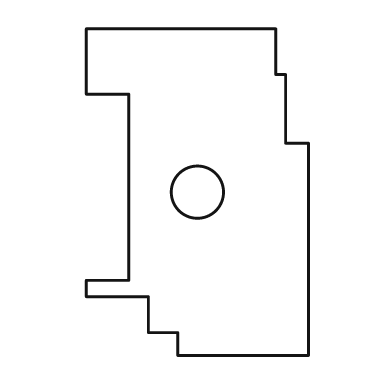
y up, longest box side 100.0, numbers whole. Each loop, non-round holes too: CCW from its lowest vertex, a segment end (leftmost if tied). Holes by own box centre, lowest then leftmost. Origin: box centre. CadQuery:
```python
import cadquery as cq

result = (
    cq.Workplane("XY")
    .moveTo(-6.0, -50.0)
    .lineTo(34.0, -50.0)
    .lineTo(34.0, 15.0)
    .lineTo(27.0, 15.0)
    .lineTo(27.0, 36.0)
    .lineTo(24.0, 36.0)
    .lineTo(24.0, 50.0)
    .lineTo(-34.0, 50.0)
    .lineTo(-34.0, 30.0)
    .lineTo(-21.0, 30.0)
    .lineTo(-21.0, -27.0)
    .lineTo(-34.0, -27.0)
    .lineTo(-34.0, -32.0)
    .lineTo(-15.0, -32.0)
    .lineTo(-15.0, -43.0)
    .lineTo(-6.0, -43.0)
    .close()
    .moveTo(0.0, 0.0)
    .circle(8.0)
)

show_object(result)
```